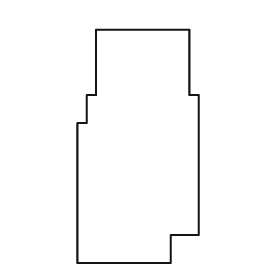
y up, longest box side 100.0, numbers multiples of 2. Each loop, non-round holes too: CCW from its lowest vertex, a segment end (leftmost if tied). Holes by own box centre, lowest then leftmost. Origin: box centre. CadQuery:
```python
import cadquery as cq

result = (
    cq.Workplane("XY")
    .moveTo(-26.0, -50.0)
    .lineTo(14.0, -50.0)
    .lineTo(14.0, -38.0)
    .lineTo(26.0, -38.0)
    .lineTo(26.0, 22.0)
    .lineTo(22.0, 22.0)
    .lineTo(22.0, 50.0)
    .lineTo(-18.0, 50.0)
    .lineTo(-18.0, 22.0)
    .lineTo(-22.0, 22.0)
    .lineTo(-22.0, 10.0)
    .lineTo(-26.0, 10.0)
    .close()
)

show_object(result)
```